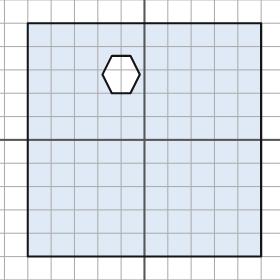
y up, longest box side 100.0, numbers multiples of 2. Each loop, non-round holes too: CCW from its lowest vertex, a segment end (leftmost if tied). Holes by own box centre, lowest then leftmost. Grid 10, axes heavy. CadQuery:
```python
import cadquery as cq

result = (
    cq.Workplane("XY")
    .moveTo(-50.0, -50.0)
    .lineTo(50.0, -50.0)
    .lineTo(50.0, 50.0)
    .lineTo(-50.0, 50.0)
    .close()
    .moveTo(-14.0, 20.0)
    .lineTo(-6.0, 20.0)
    .lineTo(-2.0, 28.0)
    .lineTo(-6.0, 36.0)
    .lineTo(-14.0, 36.0)
    .lineTo(-18.0, 28.0)
    .close()
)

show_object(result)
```